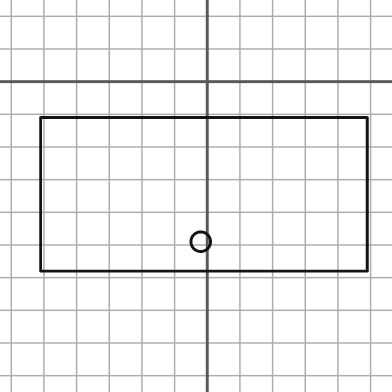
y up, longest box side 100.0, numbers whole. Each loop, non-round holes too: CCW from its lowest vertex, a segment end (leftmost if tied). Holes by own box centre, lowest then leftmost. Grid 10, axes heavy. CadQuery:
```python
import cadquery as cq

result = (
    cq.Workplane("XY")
    .moveTo(-51.0, -58.0)
    .lineTo(49.0, -58.0)
    .lineTo(49.0, -11.0)
    .lineTo(-51.0, -11.0)
    .close()
    .moveTo(-2.0, -49.0)
    .circle(3.0)
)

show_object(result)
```